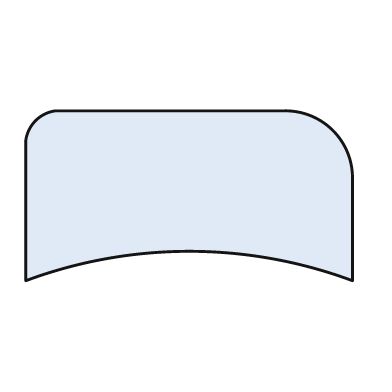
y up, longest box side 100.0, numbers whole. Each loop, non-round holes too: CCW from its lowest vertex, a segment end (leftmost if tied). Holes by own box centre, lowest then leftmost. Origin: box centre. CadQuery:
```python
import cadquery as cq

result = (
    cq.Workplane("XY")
    .moveTo(-50.0, -26.0)
    .threePointArc((0.0, -17.0), (50.0, -26.0))
    .lineTo(50.0, 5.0)
    .threePointArc((44.0, 20.0), (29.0, 26.0))
    .lineTo(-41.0, 26.0)
    .threePointArc((-47.0, 23.0), (-50.0, 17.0))
    .close()
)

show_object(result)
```